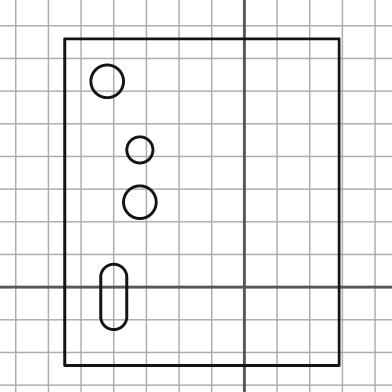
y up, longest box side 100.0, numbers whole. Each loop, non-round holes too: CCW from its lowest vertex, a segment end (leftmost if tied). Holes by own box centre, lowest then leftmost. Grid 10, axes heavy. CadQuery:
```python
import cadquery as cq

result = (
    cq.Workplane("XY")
    .moveTo(-55.0, -24.0)
    .lineTo(29.0, -24.0)
    .lineTo(29.0, 76.0)
    .lineTo(-55.0, 76.0)
    .close()
    .moveTo(-44.0, -9.0)
    .threePointArc((-40.0, -13.0), (-36.0, -9.0))
    .lineTo(-36.0, 3.0)
    .threePointArc((-40.0, 7.0), (-44.0, 3.0))
    .close()
    .moveTo(-32.0, 26.0)
    .circle(5.0)
    .moveTo(-32.0, 42.0)
    .circle(4.0)
    .moveTo(-42.0, 63.0)
    .circle(5.0)
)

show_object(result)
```